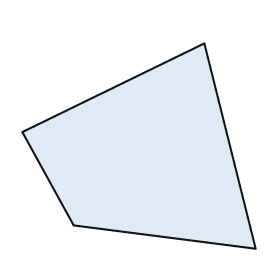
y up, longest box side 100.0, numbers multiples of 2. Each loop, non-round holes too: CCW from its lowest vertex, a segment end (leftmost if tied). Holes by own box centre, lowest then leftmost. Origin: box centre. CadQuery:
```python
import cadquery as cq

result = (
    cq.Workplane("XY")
    .moveTo(50.0, -44.0)
    .lineTo(28.0, 44.0)
    .lineTo(-50.0, 6.0)
    .lineTo(-28.0, -34.0)
    .close()
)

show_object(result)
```